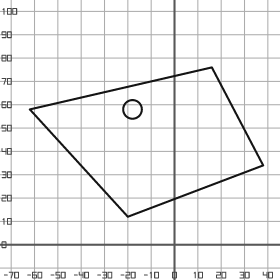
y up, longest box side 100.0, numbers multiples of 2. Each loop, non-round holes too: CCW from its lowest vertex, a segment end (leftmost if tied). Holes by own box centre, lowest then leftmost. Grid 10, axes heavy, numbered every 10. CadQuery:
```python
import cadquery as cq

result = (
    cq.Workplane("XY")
    .moveTo(-20.0, 12.0)
    .lineTo(38.0, 34.0)
    .lineTo(16.0, 76.0)
    .lineTo(-62.0, 58.0)
    .close()
    .moveTo(-18.0, 58.0)
    .circle(4.0)
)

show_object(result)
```